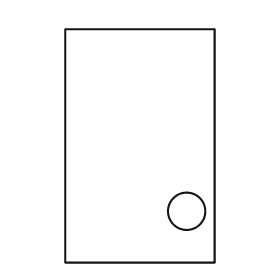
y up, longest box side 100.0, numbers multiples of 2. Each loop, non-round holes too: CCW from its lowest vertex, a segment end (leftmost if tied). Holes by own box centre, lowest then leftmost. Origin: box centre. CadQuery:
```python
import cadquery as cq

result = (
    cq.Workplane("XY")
    .moveTo(-32.0, -50.0)
    .lineTo(32.0, -50.0)
    .lineTo(32.0, 50.0)
    .lineTo(-32.0, 50.0)
    .close()
    .moveTo(20.0, -28.0)
    .circle(8.0)
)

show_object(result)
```